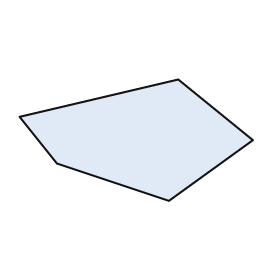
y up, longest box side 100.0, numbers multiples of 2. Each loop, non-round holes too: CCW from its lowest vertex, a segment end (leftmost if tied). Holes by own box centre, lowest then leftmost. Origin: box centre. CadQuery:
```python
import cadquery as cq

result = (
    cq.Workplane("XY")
    .moveTo(14.0, -26.0)
    .lineTo(50.0, 0.0)
    .lineTo(18.0, 26.0)
    .lineTo(-50.0, 10.0)
    .lineTo(-34.0, -10.0)
    .close()
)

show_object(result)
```